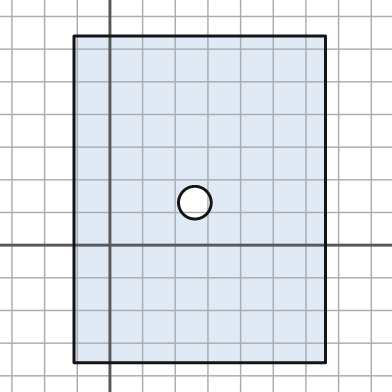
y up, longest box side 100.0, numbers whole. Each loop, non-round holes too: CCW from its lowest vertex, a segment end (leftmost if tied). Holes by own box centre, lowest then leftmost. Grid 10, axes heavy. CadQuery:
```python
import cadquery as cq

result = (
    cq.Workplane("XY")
    .moveTo(-11.0, -36.0)
    .lineTo(66.0, -36.0)
    .lineTo(66.0, 64.0)
    .lineTo(-11.0, 64.0)
    .close()
    .moveTo(26.0, 13.0)
    .circle(5.0)
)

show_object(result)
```